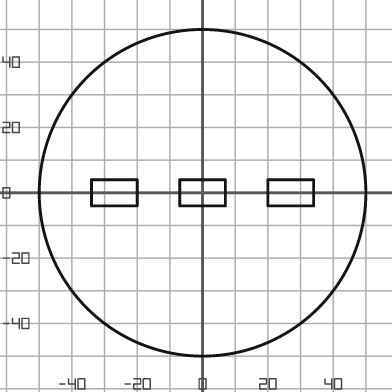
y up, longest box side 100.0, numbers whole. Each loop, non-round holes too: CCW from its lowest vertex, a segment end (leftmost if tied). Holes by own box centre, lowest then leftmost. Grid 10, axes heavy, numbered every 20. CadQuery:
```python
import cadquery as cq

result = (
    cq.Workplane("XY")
    .moveTo(0.0, 0.0)
    .circle(50.0)
    .moveTo(-34.0, -4.0)
    .lineTo(-20.0, -4.0)
    .lineTo(-20.0, 4.0)
    .lineTo(-34.0, 4.0)
    .close()
    .moveTo(-7.0, -4.0)
    .lineTo(7.0, -4.0)
    .lineTo(7.0, 4.0)
    .lineTo(-7.0, 4.0)
    .close()
    .moveTo(20.0, -4.0)
    .lineTo(34.0, -4.0)
    .lineTo(34.0, 4.0)
    .lineTo(20.0, 4.0)
    .close()
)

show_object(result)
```